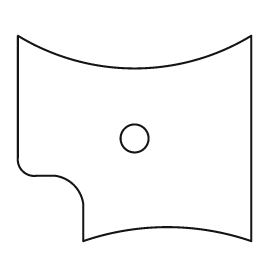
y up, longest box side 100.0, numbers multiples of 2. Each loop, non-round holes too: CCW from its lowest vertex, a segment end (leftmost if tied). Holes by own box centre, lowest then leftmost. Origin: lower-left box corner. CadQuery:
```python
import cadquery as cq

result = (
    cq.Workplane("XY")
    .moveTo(28.0, 0.0)
    .threePointArc((64.0, 6.0), (100.0, 0.0))
    .lineTo(100.0, 88.0)
    .threePointArc((50.0, 74.0), (0.0, 88.0))
    .lineTo(0.0, 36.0)
    .threePointArc((2.0, 30.0), (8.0, 28.0))
    .lineTo(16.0, 28.0)
    .threePointArc((24.0, 24.0), (28.0, 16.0))
    .close()
    .moveTo(50.0, 44.0)
    .circle(6.0)
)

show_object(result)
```